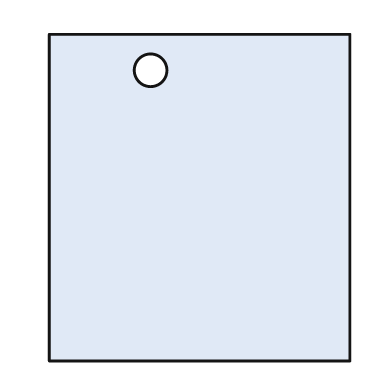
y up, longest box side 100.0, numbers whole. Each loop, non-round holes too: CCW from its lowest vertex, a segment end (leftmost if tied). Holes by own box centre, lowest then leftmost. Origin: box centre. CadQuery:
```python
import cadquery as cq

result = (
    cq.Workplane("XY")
    .moveTo(-46.0, -50.0)
    .lineTo(46.0, -50.0)
    .lineTo(46.0, 50.0)
    .lineTo(-46.0, 50.0)
    .close()
    .moveTo(-15.0, 39.0)
    .circle(5.0)
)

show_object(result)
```